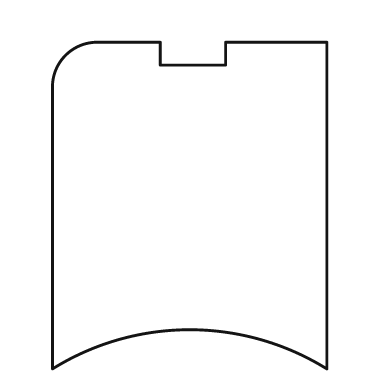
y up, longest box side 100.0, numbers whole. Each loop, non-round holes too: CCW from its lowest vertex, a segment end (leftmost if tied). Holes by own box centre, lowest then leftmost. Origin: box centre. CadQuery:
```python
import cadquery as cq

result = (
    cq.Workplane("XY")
    .moveTo(-42.0, -50.0)
    .threePointArc((0.0, -38.0), (42.0, -50.0))
    .lineTo(42.0, 50.0)
    .lineTo(11.0, 50.0)
    .lineTo(11.0, 43.0)
    .lineTo(-9.0, 43.0)
    .lineTo(-9.0, 50.0)
    .lineTo(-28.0, 50.0)
    .threePointArc((-38.0, 46.0), (-42.0, 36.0))
    .close()
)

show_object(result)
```